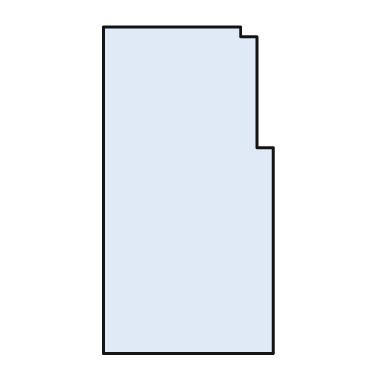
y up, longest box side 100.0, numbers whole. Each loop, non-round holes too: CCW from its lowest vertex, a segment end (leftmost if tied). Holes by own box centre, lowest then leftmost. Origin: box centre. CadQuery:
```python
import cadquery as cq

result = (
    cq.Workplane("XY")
    .moveTo(-26.0, -50.0)
    .lineTo(26.0, -50.0)
    .lineTo(26.0, 13.0)
    .lineTo(21.0, 13.0)
    .lineTo(21.0, 47.0)
    .lineTo(16.0, 47.0)
    .lineTo(16.0, 50.0)
    .lineTo(-26.0, 50.0)
    .close()
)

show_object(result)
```